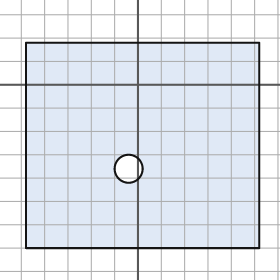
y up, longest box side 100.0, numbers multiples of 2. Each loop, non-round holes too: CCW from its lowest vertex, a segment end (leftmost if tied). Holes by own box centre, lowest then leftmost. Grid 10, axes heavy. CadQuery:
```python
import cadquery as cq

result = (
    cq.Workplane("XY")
    .moveTo(-48.0, -70.0)
    .lineTo(52.0, -70.0)
    .lineTo(52.0, 18.0)
    .lineTo(-48.0, 18.0)
    .close()
    .moveTo(-4.0, -36.0)
    .circle(6.0)
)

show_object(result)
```